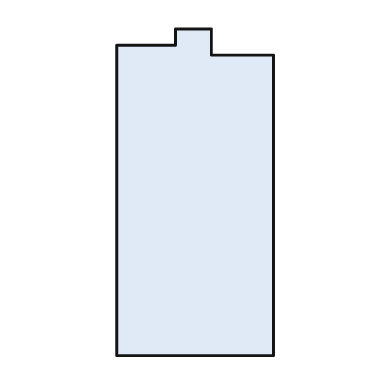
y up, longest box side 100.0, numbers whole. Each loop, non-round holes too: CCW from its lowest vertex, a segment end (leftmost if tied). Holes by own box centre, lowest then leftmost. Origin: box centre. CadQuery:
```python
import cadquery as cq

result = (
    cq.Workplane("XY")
    .moveTo(-24.0, -50.0)
    .lineTo(24.0, -50.0)
    .lineTo(24.0, 42.0)
    .lineTo(5.0, 42.0)
    .lineTo(5.0, 50.0)
    .lineTo(-6.0, 50.0)
    .lineTo(-6.0, 45.0)
    .lineTo(-24.0, 45.0)
    .close()
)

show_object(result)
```